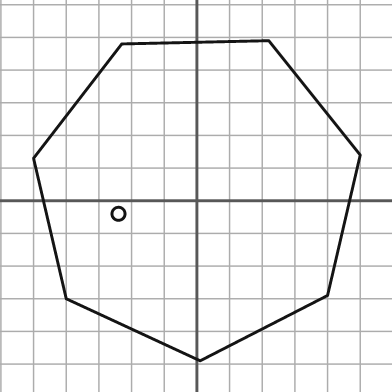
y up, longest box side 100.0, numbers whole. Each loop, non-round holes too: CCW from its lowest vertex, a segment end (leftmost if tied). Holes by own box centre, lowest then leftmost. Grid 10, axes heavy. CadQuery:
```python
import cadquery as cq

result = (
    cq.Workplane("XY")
    .moveTo(1.0, -49.0)
    .lineTo(40.0, -29.0)
    .lineTo(50.0, 14.0)
    .lineTo(22.0, 49.0)
    .lineTo(-23.0, 48.0)
    .lineTo(-50.0, 13.0)
    .lineTo(-40.0, -30.0)
    .close()
    .moveTo(-24.0, -4.0)
    .circle(2.0)
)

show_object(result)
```